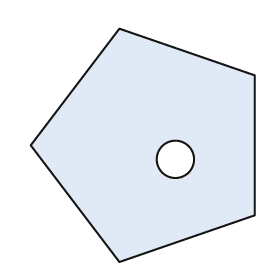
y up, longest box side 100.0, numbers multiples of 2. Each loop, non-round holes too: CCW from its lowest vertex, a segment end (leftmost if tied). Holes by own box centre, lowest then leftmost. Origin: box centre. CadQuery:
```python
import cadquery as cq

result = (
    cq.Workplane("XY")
    .moveTo(-10.0, -50.0)
    .lineTo(48.0, -30.0)
    .lineTo(48.0, 30.0)
    .lineTo(-10.0, 50.0)
    .lineTo(-48.0, 0.0)
    .close()
    .moveTo(14.0, -6.0)
    .circle(8.0)
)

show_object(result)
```